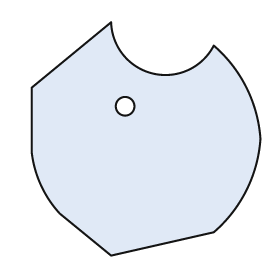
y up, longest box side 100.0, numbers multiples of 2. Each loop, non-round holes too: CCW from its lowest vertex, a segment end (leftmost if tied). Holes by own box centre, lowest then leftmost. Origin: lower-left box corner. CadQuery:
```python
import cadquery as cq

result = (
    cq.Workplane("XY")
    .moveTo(34.0, 0.0)
    .lineTo(78.0, 10.0)
    .threePointArc((92.0, 28.0), (98.0, 50.0))
    .threePointArc((92.0, 72.0), (78.0, 90.0))
    .threePointArc((52.0, 78.0), (34.0, 100.0))
    .lineTo(0.0, 72.0)
    .lineTo(0.0, 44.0)
    .threePointArc((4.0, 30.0), (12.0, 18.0))
    .close()
    .moveTo(40.0, 64.0)
    .circle(4.0)
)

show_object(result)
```